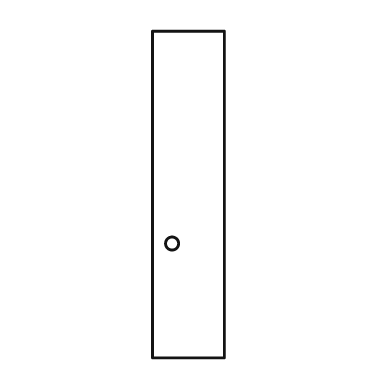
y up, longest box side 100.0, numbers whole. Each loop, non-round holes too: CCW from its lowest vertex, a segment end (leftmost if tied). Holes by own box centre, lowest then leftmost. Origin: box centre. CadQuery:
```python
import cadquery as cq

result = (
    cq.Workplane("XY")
    .moveTo(-11.0, -50.0)
    .lineTo(11.0, -50.0)
    .lineTo(11.0, 50.0)
    .lineTo(-11.0, 50.0)
    .close()
    .moveTo(-5.0, -15.0)
    .circle(2.0)
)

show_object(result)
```